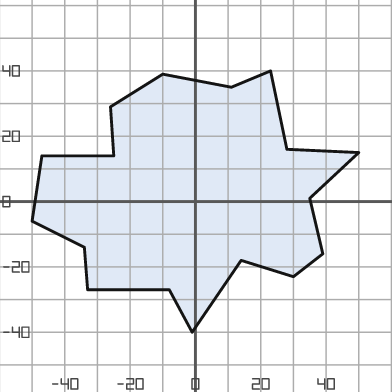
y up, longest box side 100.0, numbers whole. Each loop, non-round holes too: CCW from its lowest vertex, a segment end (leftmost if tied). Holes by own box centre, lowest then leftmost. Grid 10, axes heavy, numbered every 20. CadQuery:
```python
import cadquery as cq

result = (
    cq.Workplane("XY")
    .moveTo(-1.0, -40.0)
    .lineTo(14.0, -18.0)
    .lineTo(30.0, -23.0)
    .lineTo(39.0, -16.0)
    .lineTo(35.0, 1.0)
    .lineTo(50.0, 15.0)
    .lineTo(28.0, 16.0)
    .lineTo(23.0, 40.0)
    .lineTo(11.0, 35.0)
    .lineTo(-10.0, 39.0)
    .lineTo(-26.0, 29.0)
    .lineTo(-25.0, 14.0)
    .lineTo(-47.0, 14.0)
    .lineTo(-50.0, -6.0)
    .lineTo(-34.0, -14.0)
    .lineTo(-33.0, -27.0)
    .lineTo(-8.0, -27.0)
    .close()
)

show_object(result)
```